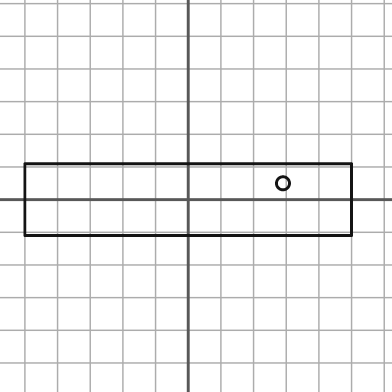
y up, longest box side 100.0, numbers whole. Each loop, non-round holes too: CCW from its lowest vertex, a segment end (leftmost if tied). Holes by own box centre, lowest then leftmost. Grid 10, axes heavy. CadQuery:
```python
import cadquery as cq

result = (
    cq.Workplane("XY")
    .moveTo(-50.0, -11.0)
    .lineTo(50.0, -11.0)
    .lineTo(50.0, 11.0)
    .lineTo(-50.0, 11.0)
    .close()
    .moveTo(29.0, 5.0)
    .circle(2.0)
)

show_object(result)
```